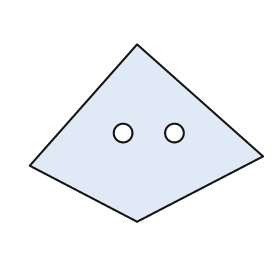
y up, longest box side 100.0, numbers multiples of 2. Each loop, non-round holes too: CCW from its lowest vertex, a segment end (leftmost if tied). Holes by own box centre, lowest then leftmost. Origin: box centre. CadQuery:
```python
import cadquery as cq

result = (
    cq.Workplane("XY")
    .moveTo(-4.0, -38.0)
    .lineTo(50.0, -10.0)
    .lineTo(-4.0, 38.0)
    .lineTo(-50.0, -14.0)
    .close()
    .moveTo(-10.0, 0.0)
    .circle(4.0)
    .moveTo(12.0, 0.0)
    .circle(4.0)
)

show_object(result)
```